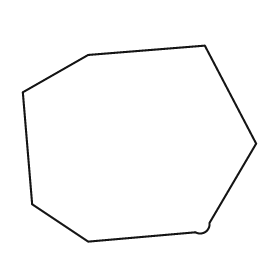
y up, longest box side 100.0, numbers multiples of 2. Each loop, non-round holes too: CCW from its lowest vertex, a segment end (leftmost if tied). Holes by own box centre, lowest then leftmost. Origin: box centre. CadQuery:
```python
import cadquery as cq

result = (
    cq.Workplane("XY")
    .moveTo(-22.0, -42.0)
    .lineTo(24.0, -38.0)
    .threePointArc((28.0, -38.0), (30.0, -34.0))
    .lineTo(50.0, 0.0)
    .lineTo(28.0, 42.0)
    .lineTo(-22.0, 38.0)
    .lineTo(-50.0, 22.0)
    .lineTo(-46.0, -26.0)
    .close()
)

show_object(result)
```